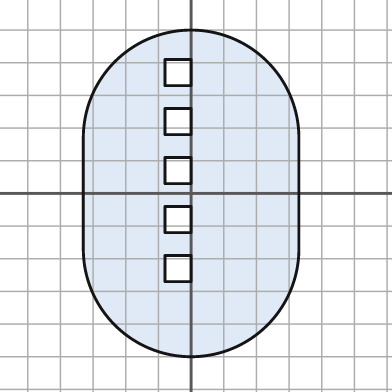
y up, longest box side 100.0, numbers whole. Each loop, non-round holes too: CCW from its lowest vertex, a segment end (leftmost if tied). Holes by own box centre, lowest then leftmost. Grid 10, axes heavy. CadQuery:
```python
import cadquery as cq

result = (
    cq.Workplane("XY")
    .moveTo(-33.0, -17.0)
    .threePointArc((0.0, -50.0), (33.0, -17.0))
    .lineTo(33.0, 17.0)
    .threePointArc((0.0, 50.0), (-33.0, 17.0))
    .close()
    .moveTo(-8.0, -27.0)
    .lineTo(0.0, -27.0)
    .lineTo(0.0, -19.0)
    .lineTo(-8.0, -19.0)
    .close()
    .moveTo(-8.0, -12.0)
    .lineTo(0.0, -12.0)
    .lineTo(0.0, -4.0)
    .lineTo(-8.0, -4.0)
    .close()
    .moveTo(-8.0, 3.0)
    .lineTo(0.0, 3.0)
    .lineTo(0.0, 11.0)
    .lineTo(-8.0, 11.0)
    .close()
    .moveTo(-8.0, 18.0)
    .lineTo(0.0, 18.0)
    .lineTo(0.0, 26.0)
    .lineTo(-8.0, 26.0)
    .close()
    .moveTo(-8.0, 33.0)
    .lineTo(0.0, 33.0)
    .lineTo(0.0, 41.0)
    .lineTo(-8.0, 41.0)
    .close()
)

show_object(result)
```